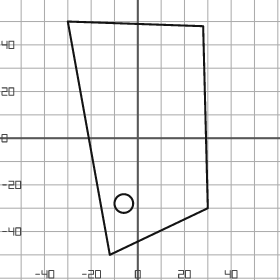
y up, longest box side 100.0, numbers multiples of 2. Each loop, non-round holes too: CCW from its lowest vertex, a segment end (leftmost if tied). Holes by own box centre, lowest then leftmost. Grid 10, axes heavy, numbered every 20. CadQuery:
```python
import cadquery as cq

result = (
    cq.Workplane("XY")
    .moveTo(-12.0, -50.0)
    .lineTo(30.0, -30.0)
    .lineTo(28.0, 48.0)
    .lineTo(-30.0, 50.0)
    .close()
    .moveTo(-6.0, -28.0)
    .circle(4.0)
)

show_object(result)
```